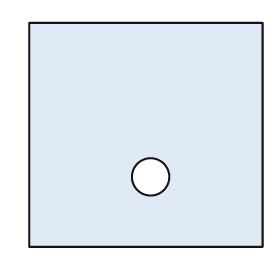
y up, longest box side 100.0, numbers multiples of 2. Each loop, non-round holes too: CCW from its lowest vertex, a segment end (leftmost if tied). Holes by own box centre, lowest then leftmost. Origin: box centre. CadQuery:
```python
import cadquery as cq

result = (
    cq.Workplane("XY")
    .moveTo(-50.0, -48.0)
    .lineTo(50.0, -48.0)
    .lineTo(50.0, 48.0)
    .lineTo(-50.0, 48.0)
    .close()
    .moveTo(2.0, -18.0)
    .circle(8.0)
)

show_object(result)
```